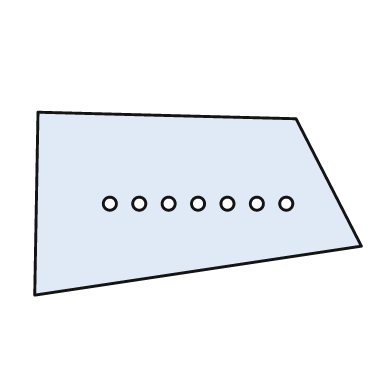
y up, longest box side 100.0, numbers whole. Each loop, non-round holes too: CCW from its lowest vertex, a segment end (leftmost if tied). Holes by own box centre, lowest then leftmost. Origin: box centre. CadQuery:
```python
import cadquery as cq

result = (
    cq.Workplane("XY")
    .moveTo(-50.0, -28.0)
    .lineTo(50.0, -13.0)
    .lineTo(30.0, 26.0)
    .lineTo(-49.0, 28.0)
    .close()
    .moveTo(-27.0, 0.0)
    .circle(2.0)
    .moveTo(-18.0, 0.0)
    .circle(2.0)
    .moveTo(-9.0, 0.0)
    .circle(2.0)
    .moveTo(0.0, 0.0)
    .circle(2.0)
    .moveTo(9.0, 0.0)
    .circle(2.0)
    .moveTo(18.0, 0.0)
    .circle(2.0)
    .moveTo(27.0, 0.0)
    .circle(2.0)
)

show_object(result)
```